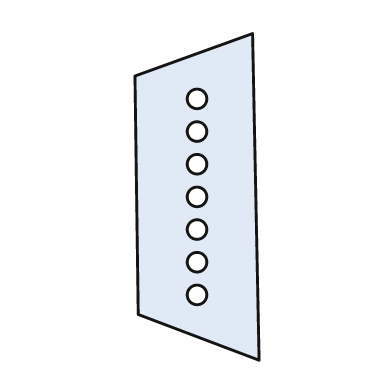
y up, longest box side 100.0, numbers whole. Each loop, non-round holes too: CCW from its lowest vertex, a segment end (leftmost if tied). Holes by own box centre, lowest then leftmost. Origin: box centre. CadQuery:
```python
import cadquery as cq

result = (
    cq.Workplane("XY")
    .moveTo(19.0, -50.0)
    .lineTo(17.0, 50.0)
    .lineTo(-19.0, 37.0)
    .lineTo(-18.0, -36.0)
    .close()
    .moveTo(0.0, -30.0)
    .circle(3.0)
    .moveTo(0.0, -20.0)
    .circle(3.0)
    .moveTo(0.0, -10.0)
    .circle(3.0)
    .moveTo(0.0, 0.0)
    .circle(3.0)
    .moveTo(0.0, 10.0)
    .circle(3.0)
    .moveTo(0.0, 20.0)
    .circle(3.0)
    .moveTo(0.0, 30.0)
    .circle(3.0)
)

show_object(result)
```